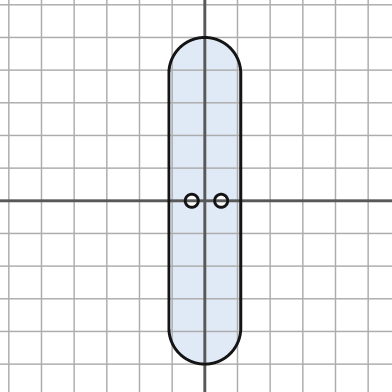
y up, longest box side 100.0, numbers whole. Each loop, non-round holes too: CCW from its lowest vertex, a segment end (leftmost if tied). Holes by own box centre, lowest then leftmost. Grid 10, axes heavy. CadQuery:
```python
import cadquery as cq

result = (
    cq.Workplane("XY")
    .moveTo(-11.0, -39.0)
    .threePointArc((0.0, -50.0), (11.0, -39.0))
    .lineTo(11.0, 39.0)
    .threePointArc((0.0, 50.0), (-11.0, 39.0))
    .close()
    .moveTo(-4.0, 0.0)
    .circle(2.0)
    .moveTo(5.0, 0.0)
    .circle(2.0)
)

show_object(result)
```